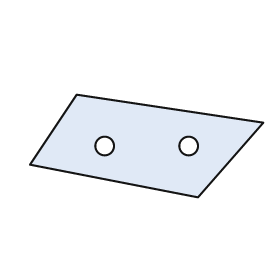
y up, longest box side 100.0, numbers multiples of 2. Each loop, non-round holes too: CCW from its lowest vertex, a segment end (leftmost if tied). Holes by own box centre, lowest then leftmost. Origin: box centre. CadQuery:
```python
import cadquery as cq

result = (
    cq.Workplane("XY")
    .moveTo(22.0, -22.0)
    .lineTo(50.0, 10.0)
    .lineTo(-30.0, 22.0)
    .lineTo(-50.0, -8.0)
    .close()
    .moveTo(-18.0, 0.0)
    .circle(4.0)
    .moveTo(18.0, 0.0)
    .circle(4.0)
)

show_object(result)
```